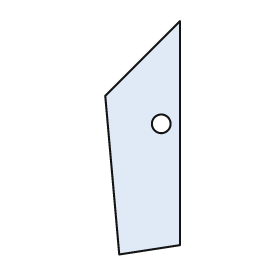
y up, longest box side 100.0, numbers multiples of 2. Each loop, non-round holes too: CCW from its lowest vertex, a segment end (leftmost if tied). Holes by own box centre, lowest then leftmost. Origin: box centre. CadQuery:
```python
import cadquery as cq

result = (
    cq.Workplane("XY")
    .moveTo(-10.0, -50.0)
    .lineTo(16.0, -46.0)
    .lineTo(16.0, 50.0)
    .lineTo(-16.0, 18.0)
    .close()
    .moveTo(8.0, 6.0)
    .circle(4.0)
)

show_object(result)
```